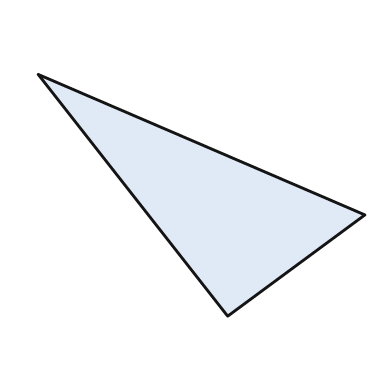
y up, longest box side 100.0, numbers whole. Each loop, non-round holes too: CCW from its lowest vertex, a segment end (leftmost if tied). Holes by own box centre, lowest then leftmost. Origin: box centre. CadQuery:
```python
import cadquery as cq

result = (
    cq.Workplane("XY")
    .moveTo(8.0, -37.0)
    .lineTo(50.0, -6.0)
    .lineTo(-50.0, 37.0)
    .close()
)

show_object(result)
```